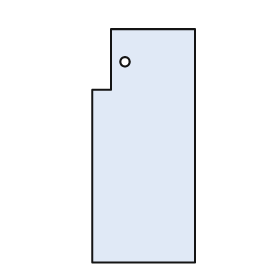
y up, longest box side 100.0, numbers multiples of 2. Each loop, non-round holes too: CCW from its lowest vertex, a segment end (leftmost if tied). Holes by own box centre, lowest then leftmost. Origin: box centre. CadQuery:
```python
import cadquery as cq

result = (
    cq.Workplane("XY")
    .moveTo(-22.0, -50.0)
    .lineTo(22.0, -50.0)
    .lineTo(22.0, 50.0)
    .lineTo(-14.0, 50.0)
    .lineTo(-14.0, 24.0)
    .lineTo(-22.0, 24.0)
    .close()
    .moveTo(-8.0, 36.0)
    .circle(2.0)
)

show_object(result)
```